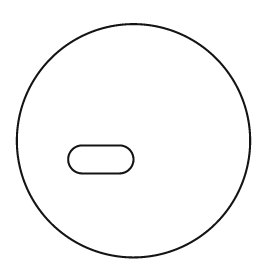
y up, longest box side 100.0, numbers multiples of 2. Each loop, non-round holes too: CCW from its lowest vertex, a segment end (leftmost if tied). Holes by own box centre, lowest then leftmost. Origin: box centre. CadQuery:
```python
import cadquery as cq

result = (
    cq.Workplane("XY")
    .moveTo(0.0, 0.0)
    .circle(50.0)
    .moveTo(-22.0, -14.0)
    .lineTo(-6.0, -14.0)
    .threePointArc((0.0, -8.0), (-6.0, -2.0))
    .lineTo(-22.0, -2.0)
    .threePointArc((-28.0, -8.0), (-22.0, -14.0))
    .close()
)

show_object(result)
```